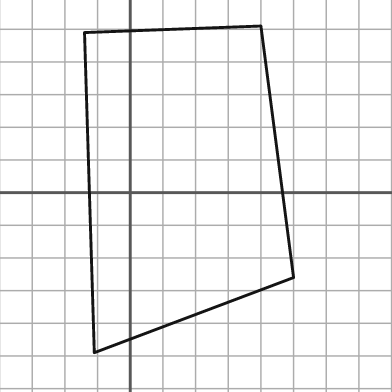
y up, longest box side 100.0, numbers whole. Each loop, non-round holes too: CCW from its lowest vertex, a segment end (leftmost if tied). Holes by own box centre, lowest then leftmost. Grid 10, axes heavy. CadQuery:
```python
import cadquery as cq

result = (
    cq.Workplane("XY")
    .moveTo(-11.0, -49.0)
    .lineTo(50.0, -26.0)
    .lineTo(40.0, 51.0)
    .lineTo(-14.0, 49.0)
    .close()
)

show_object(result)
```